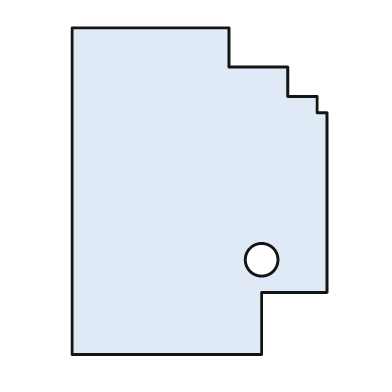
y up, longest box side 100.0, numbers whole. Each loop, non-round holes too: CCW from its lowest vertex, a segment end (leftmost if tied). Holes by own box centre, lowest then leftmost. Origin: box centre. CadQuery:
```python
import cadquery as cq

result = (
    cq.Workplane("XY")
    .moveTo(-39.0, -50.0)
    .lineTo(19.0, -50.0)
    .lineTo(19.0, -31.0)
    .lineTo(39.0, -31.0)
    .lineTo(39.0, 24.0)
    .lineTo(36.0, 24.0)
    .lineTo(36.0, 29.0)
    .lineTo(27.0, 29.0)
    .lineTo(27.0, 38.0)
    .lineTo(9.0, 38.0)
    .lineTo(9.0, 50.0)
    .lineTo(-39.0, 50.0)
    .close()
    .moveTo(19.0, -21.0)
    .circle(5.0)
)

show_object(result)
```